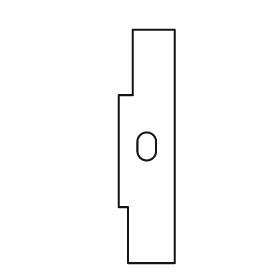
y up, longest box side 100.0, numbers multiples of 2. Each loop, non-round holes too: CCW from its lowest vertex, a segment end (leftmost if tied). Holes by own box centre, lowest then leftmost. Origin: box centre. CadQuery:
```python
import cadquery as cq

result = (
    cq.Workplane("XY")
    .moveTo(-8.0, -50.0)
    .lineTo(12.0, -50.0)
    .lineTo(12.0, 50.0)
    .lineTo(-6.0, 50.0)
    .lineTo(-6.0, 22.0)
    .lineTo(-12.0, 22.0)
    .lineTo(-12.0, -26.0)
    .lineTo(-8.0, -26.0)
    .close()
    .moveTo(-4.0, -2.0)
    .threePointArc((0.0, -6.0), (4.0, -2.0))
    .lineTo(4.0, 2.0)
    .threePointArc((0.0, 6.0), (-4.0, 2.0))
    .close()
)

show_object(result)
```